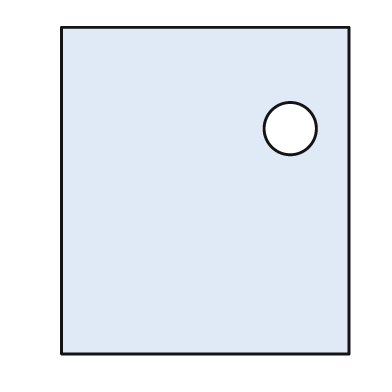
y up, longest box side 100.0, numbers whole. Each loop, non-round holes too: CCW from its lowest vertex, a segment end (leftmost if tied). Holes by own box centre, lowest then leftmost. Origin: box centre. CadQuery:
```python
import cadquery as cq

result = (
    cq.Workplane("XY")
    .moveTo(-44.0, -50.0)
    .lineTo(44.0, -50.0)
    .lineTo(44.0, 50.0)
    .lineTo(-44.0, 50.0)
    .close()
    .moveTo(26.0, 19.0)
    .circle(8.0)
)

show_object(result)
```